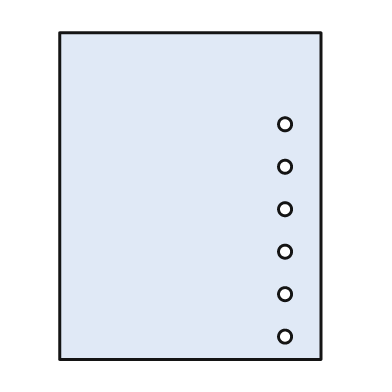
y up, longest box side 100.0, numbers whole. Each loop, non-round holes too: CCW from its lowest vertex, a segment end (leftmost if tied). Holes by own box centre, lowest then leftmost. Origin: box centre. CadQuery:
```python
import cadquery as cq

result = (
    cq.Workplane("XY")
    .moveTo(-40.0, -50.0)
    .lineTo(40.0, -50.0)
    .lineTo(40.0, 50.0)
    .lineTo(-40.0, 50.0)
    .close()
    .moveTo(29.0, -43.0)
    .circle(2.0)
    .moveTo(29.0, -30.0)
    .circle(2.0)
    .moveTo(29.0, -17.0)
    .circle(2.0)
    .moveTo(29.0, -4.0)
    .circle(2.0)
    .moveTo(29.0, 9.0)
    .circle(2.0)
    .moveTo(29.0, 22.0)
    .circle(2.0)
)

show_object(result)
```